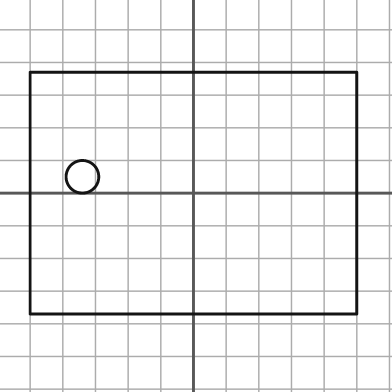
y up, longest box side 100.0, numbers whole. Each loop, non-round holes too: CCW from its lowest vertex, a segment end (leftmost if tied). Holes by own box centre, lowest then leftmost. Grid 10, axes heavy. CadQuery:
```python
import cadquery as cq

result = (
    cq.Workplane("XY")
    .moveTo(-50.0, -37.0)
    .lineTo(50.0, -37.0)
    .lineTo(50.0, 37.0)
    .lineTo(-50.0, 37.0)
    .close()
    .moveTo(-34.0, 5.0)
    .circle(5.0)
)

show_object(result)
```